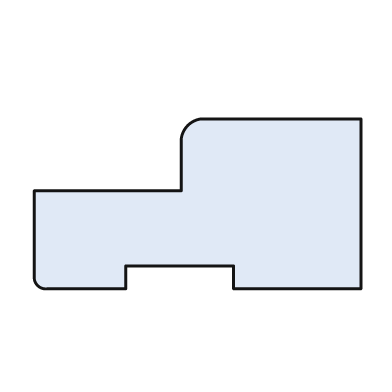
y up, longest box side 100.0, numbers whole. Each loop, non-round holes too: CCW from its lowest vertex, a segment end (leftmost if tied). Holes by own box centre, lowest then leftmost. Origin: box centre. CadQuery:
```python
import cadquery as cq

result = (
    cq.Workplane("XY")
    .moveTo(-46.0, -26.0)
    .lineTo(-22.0, -26.0)
    .lineTo(-22.0, -19.0)
    .lineTo(11.0, -19.0)
    .lineTo(11.0, -26.0)
    .lineTo(50.0, -26.0)
    .lineTo(50.0, 26.0)
    .lineTo(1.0, 26.0)
    .threePointArc((-3.0, 24.0), (-5.0, 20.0))
    .lineTo(-5.0, 4.0)
    .lineTo(-50.0, 4.0)
    .lineTo(-50.0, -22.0)
    .threePointArc((-49.0, -25.0), (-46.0, -26.0))
    .close()
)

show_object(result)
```